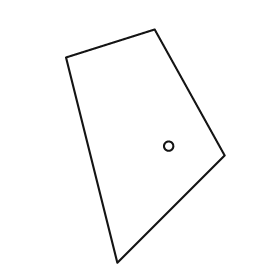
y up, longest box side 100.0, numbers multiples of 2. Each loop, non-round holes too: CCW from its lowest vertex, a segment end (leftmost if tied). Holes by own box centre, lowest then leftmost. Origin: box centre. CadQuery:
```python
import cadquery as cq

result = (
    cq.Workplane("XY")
    .moveTo(-12.0, -50.0)
    .lineTo(34.0, -4.0)
    .lineTo(4.0, 50.0)
    .lineTo(-34.0, 38.0)
    .close()
    .moveTo(10.0, 0.0)
    .circle(2.0)
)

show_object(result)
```